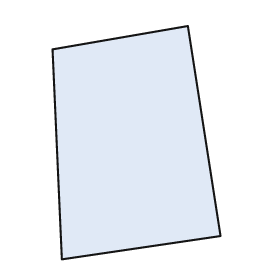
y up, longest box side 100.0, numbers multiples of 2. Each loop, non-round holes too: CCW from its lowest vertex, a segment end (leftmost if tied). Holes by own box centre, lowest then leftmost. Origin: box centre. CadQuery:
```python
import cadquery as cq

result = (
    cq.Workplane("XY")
    .moveTo(-32.0, -50.0)
    .lineTo(36.0, -40.0)
    .lineTo(22.0, 50.0)
    .lineTo(-36.0, 40.0)
    .close()
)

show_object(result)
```